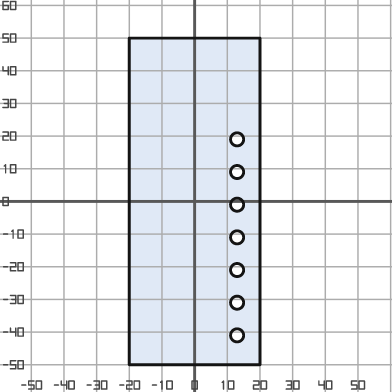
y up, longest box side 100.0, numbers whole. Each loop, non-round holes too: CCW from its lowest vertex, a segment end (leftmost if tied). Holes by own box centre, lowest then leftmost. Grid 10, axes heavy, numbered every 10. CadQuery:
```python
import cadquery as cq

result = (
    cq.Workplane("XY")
    .moveTo(-20.0, -50.0)
    .lineTo(20.0, -50.0)
    .lineTo(20.0, 50.0)
    .lineTo(-20.0, 50.0)
    .close()
    .moveTo(13.0, -41.0)
    .circle(2.0)
    .moveTo(13.0, -31.0)
    .circle(2.0)
    .moveTo(13.0, -21.0)
    .circle(2.0)
    .moveTo(13.0, -11.0)
    .circle(2.0)
    .moveTo(13.0, -1.0)
    .circle(2.0)
    .moveTo(13.0, 9.0)
    .circle(2.0)
    .moveTo(13.0, 19.0)
    .circle(2.0)
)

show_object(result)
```